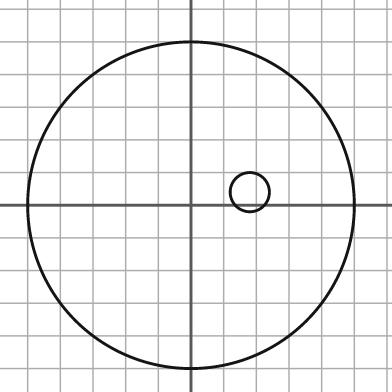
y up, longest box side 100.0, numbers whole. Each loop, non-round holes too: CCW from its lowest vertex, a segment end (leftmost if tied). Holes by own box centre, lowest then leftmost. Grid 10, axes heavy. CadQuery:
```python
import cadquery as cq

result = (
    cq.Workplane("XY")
    .moveTo(0.0, 0.0)
    .circle(50.0)
    .moveTo(18.0, 4.0)
    .circle(6.0)
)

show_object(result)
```